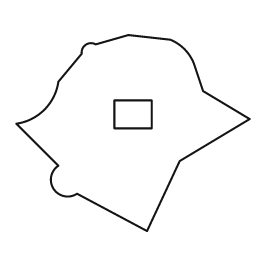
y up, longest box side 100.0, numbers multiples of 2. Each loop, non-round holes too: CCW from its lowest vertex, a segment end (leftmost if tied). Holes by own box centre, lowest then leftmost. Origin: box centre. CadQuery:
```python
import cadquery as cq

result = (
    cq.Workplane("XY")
    .moveTo(6.0, -42.0)
    .lineTo(20.0, -12.0)
    .lineTo(50.0, 6.0)
    .lineTo(30.0, 18.0)
    .lineTo(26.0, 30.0)
    .threePointArc((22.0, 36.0), (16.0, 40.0))
    .lineTo(-2.0, 42.0)
    .lineTo(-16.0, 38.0)
    .threePointArc((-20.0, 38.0), (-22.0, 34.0))
    .lineTo(-32.0, 22.0)
    .threePointArc((-38.0, 10.0), (-50.0, 4.0))
    .lineTo(-32.0, -14.0)
    .threePointArc((-34.0, -24.0), (-24.0, -26.0))
    .close()
    .moveTo(-8.0, 2.0)
    .lineTo(8.0, 2.0)
    .lineTo(8.0, 14.0)
    .lineTo(-8.0, 14.0)
    .close()
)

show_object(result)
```